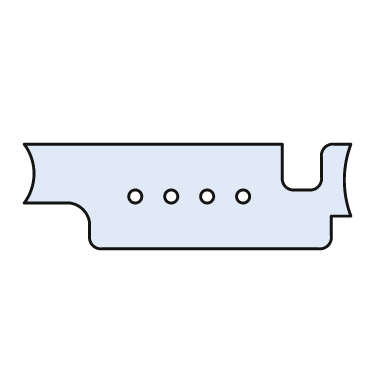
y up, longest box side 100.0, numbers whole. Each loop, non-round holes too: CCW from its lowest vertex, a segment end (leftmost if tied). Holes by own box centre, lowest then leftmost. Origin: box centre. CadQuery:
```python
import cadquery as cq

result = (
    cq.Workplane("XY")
    .moveTo(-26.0, -16.0)
    .lineTo(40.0, -16.0)
    .threePointArc((43.0, -15.0), (44.0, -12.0))
    .lineTo(44.0, -6.0)
    .lineTo(50.0, -6.0)
    .threePointArc((48.0, 5.0), (50.0, 16.0))
    .lineTo(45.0, 16.0)
    .threePointArc((42.0, 15.0), (41.0, 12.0))
    .lineTo(41.0, 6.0)
    .threePointArc((40.0, 3.0), (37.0, 2.0))
    .lineTo(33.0, 2.0)
    .threePointArc((30.0, 3.0), (29.0, 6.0))
    .lineTo(29.0, 16.0)
    .lineTo(-50.0, 16.0)
    .threePointArc((-47.0, 7.0), (-50.0, -2.0))
    .lineTo(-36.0, -2.0)
    .threePointArc((-32.0, -4.0), (-30.0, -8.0))
    .lineTo(-30.0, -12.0)
    .threePointArc((-29.0, -15.0), (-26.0, -16.0))
    .close()
    .moveTo(-16.0, 0.0)
    .circle(2.0)
    .moveTo(-5.0, 0.0)
    .circle(2.0)
    .moveTo(6.0, 0.0)
    .circle(2.0)
    .moveTo(17.0, 0.0)
    .circle(2.0)
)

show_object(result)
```